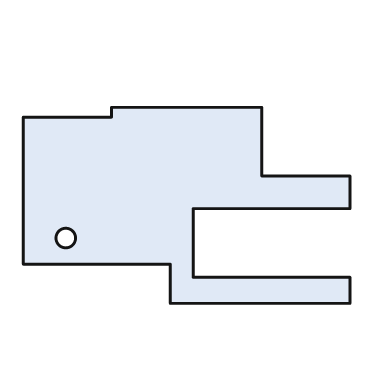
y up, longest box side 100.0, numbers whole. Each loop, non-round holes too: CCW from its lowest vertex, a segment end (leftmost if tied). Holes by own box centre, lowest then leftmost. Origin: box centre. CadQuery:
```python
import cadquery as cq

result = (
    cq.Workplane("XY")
    .moveTo(-5.0, -30.0)
    .lineTo(50.0, -30.0)
    .lineTo(50.0, -22.0)
    .lineTo(2.0, -22.0)
    .lineTo(2.0, -1.0)
    .lineTo(50.0, -1.0)
    .lineTo(50.0, 9.0)
    .lineTo(23.0, 9.0)
    .lineTo(23.0, 30.0)
    .lineTo(-23.0, 30.0)
    .lineTo(-23.0, 27.0)
    .lineTo(-50.0, 27.0)
    .lineTo(-50.0, -18.0)
    .lineTo(-5.0, -18.0)
    .close()
    .moveTo(-37.0, -10.0)
    .circle(3.0)
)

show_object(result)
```